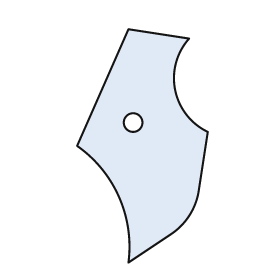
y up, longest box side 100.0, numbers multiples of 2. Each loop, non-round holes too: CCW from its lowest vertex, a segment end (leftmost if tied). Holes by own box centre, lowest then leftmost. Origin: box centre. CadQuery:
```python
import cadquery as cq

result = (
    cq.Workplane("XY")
    .moveTo(-6.0, -50.0)
    .lineTo(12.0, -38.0)
    .threePointArc((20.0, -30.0), (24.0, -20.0))
    .lineTo(28.0, 6.0)
    .threePointArc((14.0, 24.0), (20.0, 46.0))
    .lineTo(-6.0, 50.0)
    .lineTo(-28.0, 0.0)
    .threePointArc((-10.0, -22.0), (-6.0, -50.0))
    .close()
    .moveTo(-4.0, 10.0)
    .circle(4.0)
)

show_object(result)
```